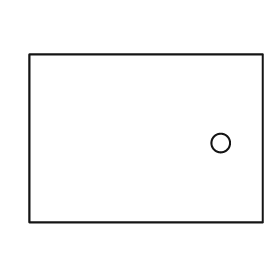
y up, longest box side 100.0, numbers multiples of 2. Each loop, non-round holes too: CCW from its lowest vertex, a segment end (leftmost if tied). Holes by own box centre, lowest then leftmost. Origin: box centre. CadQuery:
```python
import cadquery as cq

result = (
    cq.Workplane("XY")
    .moveTo(-50.0, -36.0)
    .lineTo(50.0, -36.0)
    .lineTo(50.0, 36.0)
    .lineTo(-50.0, 36.0)
    .close()
    .moveTo(32.0, -2.0)
    .circle(4.0)
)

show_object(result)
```